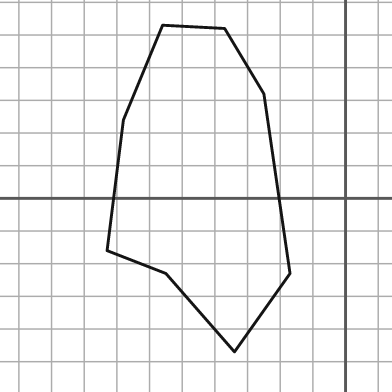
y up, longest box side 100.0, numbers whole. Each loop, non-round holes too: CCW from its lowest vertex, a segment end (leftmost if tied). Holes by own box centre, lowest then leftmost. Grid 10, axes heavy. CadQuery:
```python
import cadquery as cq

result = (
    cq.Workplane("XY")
    .moveTo(-34.0, -47.0)
    .lineTo(-17.0, -23.0)
    .lineTo(-25.0, 32.0)
    .lineTo(-37.0, 52.0)
    .lineTo(-56.0, 53.0)
    .lineTo(-68.0, 24.0)
    .lineTo(-73.0, -16.0)
    .lineTo(-55.0, -23.0)
    .close()
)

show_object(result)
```